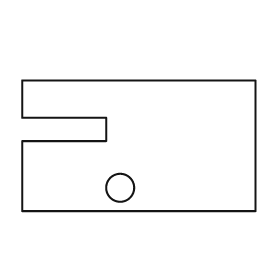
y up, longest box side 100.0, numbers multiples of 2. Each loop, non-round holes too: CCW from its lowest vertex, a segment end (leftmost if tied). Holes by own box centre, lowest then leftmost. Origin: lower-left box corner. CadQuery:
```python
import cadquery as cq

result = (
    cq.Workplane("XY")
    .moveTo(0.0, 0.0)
    .lineTo(100.0, 0.0)
    .lineTo(100.0, 56.0)
    .lineTo(0.0, 56.0)
    .lineTo(0.0, 40.0)
    .lineTo(36.0, 40.0)
    .lineTo(36.0, 30.0)
    .lineTo(0.0, 30.0)
    .close()
    .moveTo(42.0, 10.0)
    .circle(6.0)
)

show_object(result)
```